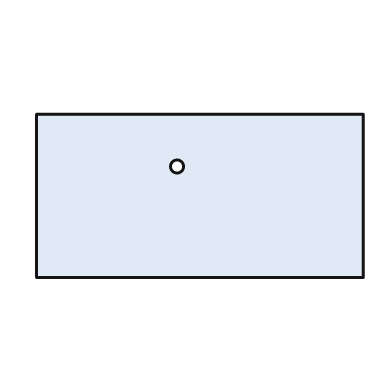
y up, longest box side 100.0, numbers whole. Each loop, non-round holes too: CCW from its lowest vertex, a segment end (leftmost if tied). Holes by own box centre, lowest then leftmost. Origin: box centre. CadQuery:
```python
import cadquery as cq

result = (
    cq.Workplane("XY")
    .moveTo(-50.0, -25.0)
    .lineTo(50.0, -25.0)
    .lineTo(50.0, 25.0)
    .lineTo(-50.0, 25.0)
    .close()
    .moveTo(-7.0, 9.0)
    .circle(2.0)
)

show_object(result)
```